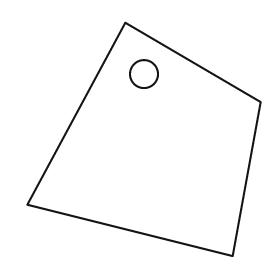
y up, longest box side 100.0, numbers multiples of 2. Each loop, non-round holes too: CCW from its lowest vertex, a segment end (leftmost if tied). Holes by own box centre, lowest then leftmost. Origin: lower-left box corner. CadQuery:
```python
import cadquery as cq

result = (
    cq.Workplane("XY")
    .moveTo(88.0, 0.0)
    .lineTo(100.0, 66.0)
    .lineTo(42.0, 100.0)
    .lineTo(0.0, 22.0)
    .close()
    .moveTo(50.0, 78.0)
    .circle(6.0)
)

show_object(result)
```